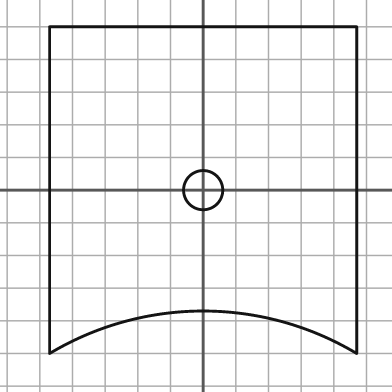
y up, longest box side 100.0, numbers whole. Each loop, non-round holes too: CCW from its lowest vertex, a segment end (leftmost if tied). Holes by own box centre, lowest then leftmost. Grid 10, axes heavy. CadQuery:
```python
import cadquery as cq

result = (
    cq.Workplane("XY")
    .moveTo(-47.0, -50.0)
    .threePointArc((0.0, -37.0), (47.0, -50.0))
    .lineTo(47.0, 50.0)
    .lineTo(-47.0, 50.0)
    .close()
    .moveTo(0.0, 0.0)
    .circle(6.0)
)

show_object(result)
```